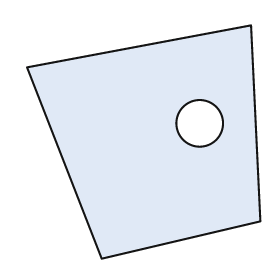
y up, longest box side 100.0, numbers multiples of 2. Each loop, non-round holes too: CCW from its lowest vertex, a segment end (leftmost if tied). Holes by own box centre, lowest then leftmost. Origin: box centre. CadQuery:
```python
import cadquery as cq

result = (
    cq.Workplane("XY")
    .moveTo(-18.0, -50.0)
    .lineTo(50.0, -34.0)
    .lineTo(46.0, 50.0)
    .lineTo(-50.0, 32.0)
    .close()
    .moveTo(24.0, 8.0)
    .circle(10.0)
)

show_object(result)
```